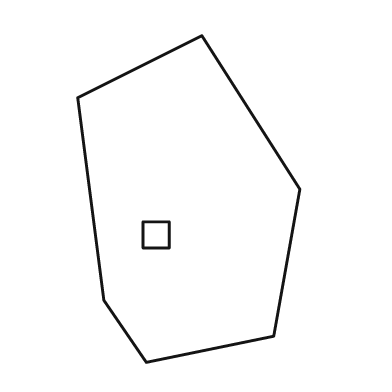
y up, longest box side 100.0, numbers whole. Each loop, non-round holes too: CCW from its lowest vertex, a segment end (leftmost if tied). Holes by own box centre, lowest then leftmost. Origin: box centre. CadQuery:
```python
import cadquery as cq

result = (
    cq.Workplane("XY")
    .moveTo(-13.0, -50.0)
    .lineTo(26.0, -42.0)
    .lineTo(34.0, 3.0)
    .lineTo(4.0, 50.0)
    .lineTo(-34.0, 31.0)
    .lineTo(-26.0, -31.0)
    .close()
    .moveTo(-14.0, -15.0)
    .lineTo(-6.0, -15.0)
    .lineTo(-6.0, -7.0)
    .lineTo(-14.0, -7.0)
    .close()
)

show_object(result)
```